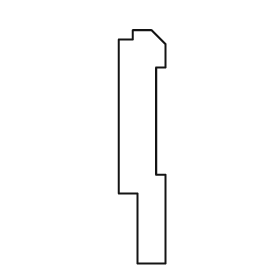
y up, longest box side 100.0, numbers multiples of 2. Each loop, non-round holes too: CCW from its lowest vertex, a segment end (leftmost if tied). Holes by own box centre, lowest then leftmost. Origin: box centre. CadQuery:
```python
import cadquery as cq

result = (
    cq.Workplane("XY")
    .moveTo(-2.0, -50.0)
    .lineTo(10.0, -50.0)
    .lineTo(10.0, -12.0)
    .lineTo(6.0, -12.0)
    .lineTo(6.0, 34.0)
    .lineTo(10.0, 34.0)
    .lineTo(10.0, 44.0)
    .lineTo(4.0, 50.0)
    .lineTo(-4.0, 50.0)
    .lineTo(-4.0, 46.0)
    .lineTo(-10.0, 46.0)
    .lineTo(-10.0, -20.0)
    .lineTo(-2.0, -20.0)
    .close()
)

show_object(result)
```